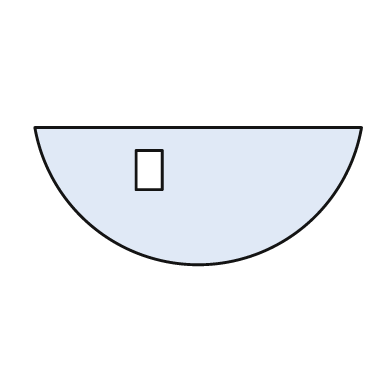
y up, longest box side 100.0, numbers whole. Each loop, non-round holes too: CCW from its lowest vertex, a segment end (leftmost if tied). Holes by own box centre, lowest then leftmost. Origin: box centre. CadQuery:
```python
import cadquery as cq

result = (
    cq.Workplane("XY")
    .moveTo(-50.0, 21.0)
    .threePointArc((0.0, -21.0), (50.0, 21.0))
    .close()
    .moveTo(-19.0, 2.0)
    .lineTo(-11.0, 2.0)
    .lineTo(-11.0, 14.0)
    .lineTo(-19.0, 14.0)
    .close()
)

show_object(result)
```